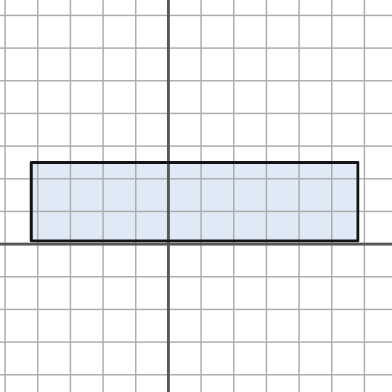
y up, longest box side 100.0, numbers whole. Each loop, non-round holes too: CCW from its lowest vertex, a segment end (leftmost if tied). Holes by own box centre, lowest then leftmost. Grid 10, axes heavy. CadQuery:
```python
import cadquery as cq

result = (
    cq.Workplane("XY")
    .moveTo(-42.0, 1.0)
    .lineTo(58.0, 1.0)
    .lineTo(58.0, 25.0)
    .lineTo(-42.0, 25.0)
    .close()
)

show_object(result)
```